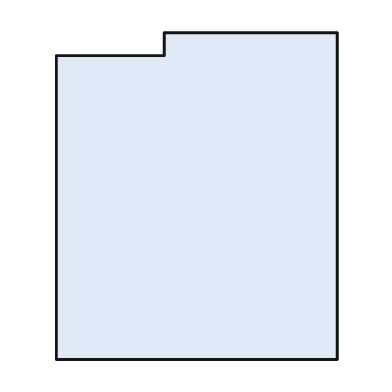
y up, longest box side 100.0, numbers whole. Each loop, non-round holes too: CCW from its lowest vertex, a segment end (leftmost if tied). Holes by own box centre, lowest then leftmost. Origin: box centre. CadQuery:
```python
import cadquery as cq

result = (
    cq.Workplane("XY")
    .moveTo(-43.0, -50.0)
    .lineTo(43.0, -50.0)
    .lineTo(43.0, 50.0)
    .lineTo(-10.0, 50.0)
    .lineTo(-10.0, 43.0)
    .lineTo(-43.0, 43.0)
    .close()
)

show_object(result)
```